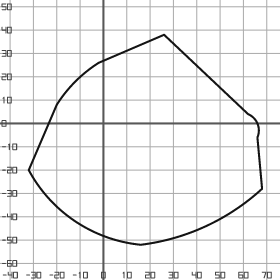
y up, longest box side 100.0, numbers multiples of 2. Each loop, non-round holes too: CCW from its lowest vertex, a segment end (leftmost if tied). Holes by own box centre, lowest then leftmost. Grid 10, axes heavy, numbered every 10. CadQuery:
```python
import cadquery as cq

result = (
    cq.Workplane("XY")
    .moveTo(16.0, -52.0)
    .threePointArc((44.0, -44.0), (68.0, -28.0))
    .lineTo(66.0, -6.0)
    .threePointArc((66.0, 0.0), (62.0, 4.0))
    .lineTo(26.0, 38.0)
    .lineTo(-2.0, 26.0)
    .threePointArc((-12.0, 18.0), (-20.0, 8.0))
    .lineTo(-32.0, -20.0)
    .threePointArc((-12.0, -42.0), (16.0, -52.0))
    .close()
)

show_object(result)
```